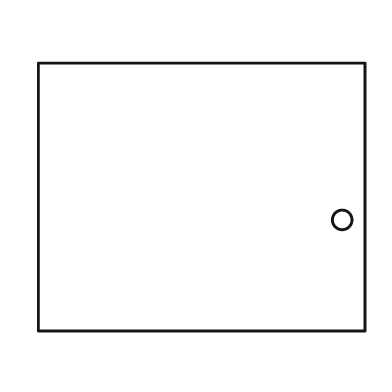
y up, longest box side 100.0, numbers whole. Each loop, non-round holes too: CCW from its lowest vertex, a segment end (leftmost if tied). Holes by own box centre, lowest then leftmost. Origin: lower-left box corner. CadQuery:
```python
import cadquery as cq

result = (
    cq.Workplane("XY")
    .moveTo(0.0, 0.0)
    .lineTo(100.0, 0.0)
    .lineTo(100.0, 82.0)
    .lineTo(0.0, 82.0)
    .close()
    .moveTo(93.0, 34.0)
    .circle(3.0)
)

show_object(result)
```